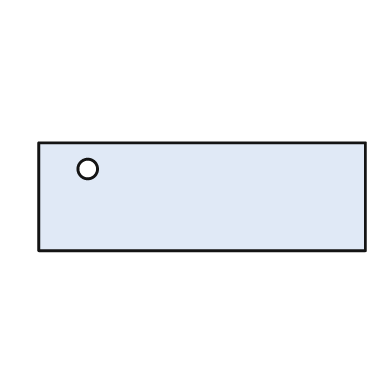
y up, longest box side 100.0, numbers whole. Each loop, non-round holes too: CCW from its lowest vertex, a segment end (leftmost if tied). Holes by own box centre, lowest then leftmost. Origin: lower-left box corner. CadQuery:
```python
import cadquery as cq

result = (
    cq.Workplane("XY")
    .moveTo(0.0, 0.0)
    .lineTo(100.0, 0.0)
    .lineTo(100.0, 33.0)
    .lineTo(0.0, 33.0)
    .close()
    .moveTo(15.0, 25.0)
    .circle(3.0)
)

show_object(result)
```